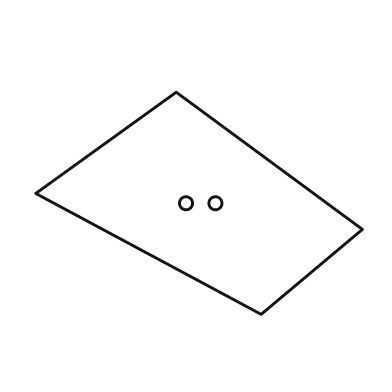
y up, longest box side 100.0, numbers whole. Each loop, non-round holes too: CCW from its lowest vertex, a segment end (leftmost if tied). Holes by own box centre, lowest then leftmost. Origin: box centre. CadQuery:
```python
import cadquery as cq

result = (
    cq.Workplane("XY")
    .moveTo(19.0, -34.0)
    .lineTo(50.0, -8.0)
    .lineTo(-7.0, 34.0)
    .lineTo(-50.0, 3.0)
    .close()
    .moveTo(-4.0, 0.0)
    .circle(2.0)
    .moveTo(5.0, 0.0)
    .circle(2.0)
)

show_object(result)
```